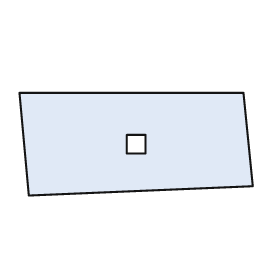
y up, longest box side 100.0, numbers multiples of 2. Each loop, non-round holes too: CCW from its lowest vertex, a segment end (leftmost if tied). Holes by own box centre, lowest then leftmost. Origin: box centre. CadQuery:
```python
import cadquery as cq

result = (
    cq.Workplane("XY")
    .moveTo(-46.0, -22.0)
    .lineTo(50.0, -18.0)
    .lineTo(46.0, 22.0)
    .lineTo(-50.0, 22.0)
    .close()
    .moveTo(-4.0, -4.0)
    .lineTo(4.0, -4.0)
    .lineTo(4.0, 4.0)
    .lineTo(-4.0, 4.0)
    .close()
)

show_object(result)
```